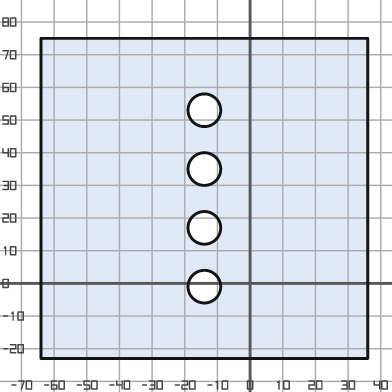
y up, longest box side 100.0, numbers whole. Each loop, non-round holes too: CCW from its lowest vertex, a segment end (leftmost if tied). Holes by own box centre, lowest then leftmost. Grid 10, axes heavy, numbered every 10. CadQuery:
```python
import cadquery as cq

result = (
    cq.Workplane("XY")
    .moveTo(-64.0, -23.0)
    .lineTo(36.0, -23.0)
    .lineTo(36.0, 75.0)
    .lineTo(-64.0, 75.0)
    .close()
    .moveTo(-14.0, -1.0)
    .circle(5.0)
    .moveTo(-14.0, 17.0)
    .circle(5.0)
    .moveTo(-14.0, 35.0)
    .circle(5.0)
    .moveTo(-14.0, 53.0)
    .circle(5.0)
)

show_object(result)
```